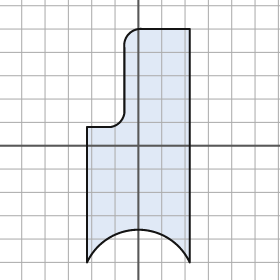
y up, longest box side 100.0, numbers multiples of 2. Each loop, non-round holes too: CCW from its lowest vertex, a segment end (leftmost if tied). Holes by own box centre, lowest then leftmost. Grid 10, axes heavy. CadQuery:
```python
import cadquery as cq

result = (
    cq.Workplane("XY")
    .moveTo(-22.0, -50.0)
    .threePointArc((0.0, -36.0), (22.0, -50.0))
    .lineTo(22.0, 50.0)
    .lineTo(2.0, 50.0)
    .threePointArc((-4.0, 48.0), (-6.0, 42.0))
    .lineTo(-6.0, 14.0)
    .threePointArc((-8.0, 10.0), (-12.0, 8.0))
    .lineTo(-22.0, 8.0)
    .close()
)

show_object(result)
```